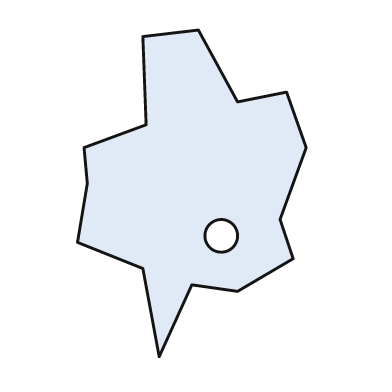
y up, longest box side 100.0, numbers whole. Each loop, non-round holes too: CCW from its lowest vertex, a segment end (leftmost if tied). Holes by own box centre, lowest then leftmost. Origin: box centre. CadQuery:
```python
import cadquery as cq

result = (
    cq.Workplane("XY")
    .moveTo(-10.0, -50.0)
    .lineTo(0.0, -28.0)
    .lineTo(14.0, -30.0)
    .lineTo(31.0, -20.0)
    .lineTo(27.0, -8.0)
    .lineTo(35.0, 14.0)
    .lineTo(29.0, 31.0)
    .lineTo(14.0, 28.0)
    .lineTo(2.0, 50.0)
    .lineTo(-15.0, 48.0)
    .lineTo(-14.0, 21.0)
    .lineTo(-33.0, 14.0)
    .lineTo(-32.0, 3.0)
    .lineTo(-35.0, -15.0)
    .lineTo(-15.0, -23.0)
    .close()
    .moveTo(9.0, -13.0)
    .circle(5.0)
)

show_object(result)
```